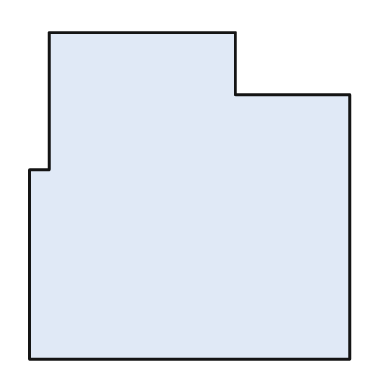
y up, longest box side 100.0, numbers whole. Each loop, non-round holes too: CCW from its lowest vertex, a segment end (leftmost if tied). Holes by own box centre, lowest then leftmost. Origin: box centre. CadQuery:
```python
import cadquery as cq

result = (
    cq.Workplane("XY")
    .moveTo(-49.0, -50.0)
    .lineTo(49.0, -50.0)
    .lineTo(49.0, 31.0)
    .lineTo(14.0, 31.0)
    .lineTo(14.0, 50.0)
    .lineTo(-43.0, 50.0)
    .lineTo(-43.0, 8.0)
    .lineTo(-49.0, 8.0)
    .close()
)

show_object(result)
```